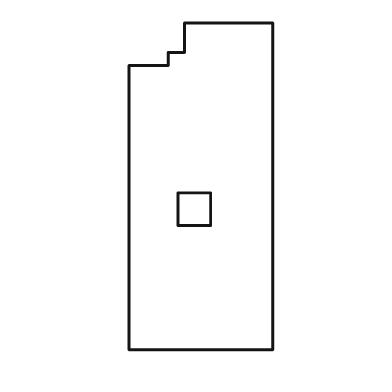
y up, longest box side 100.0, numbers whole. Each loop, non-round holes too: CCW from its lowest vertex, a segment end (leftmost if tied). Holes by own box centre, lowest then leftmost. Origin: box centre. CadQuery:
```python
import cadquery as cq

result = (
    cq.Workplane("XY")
    .moveTo(-22.0, -50.0)
    .lineTo(22.0, -50.0)
    .lineTo(22.0, 50.0)
    .lineTo(-5.0, 50.0)
    .lineTo(-5.0, 41.0)
    .lineTo(-10.0, 41.0)
    .lineTo(-10.0, 37.0)
    .lineTo(-22.0, 37.0)
    .close()
    .moveTo(-7.0, -12.0)
    .lineTo(3.0, -12.0)
    .lineTo(3.0, -2.0)
    .lineTo(-7.0, -2.0)
    .close()
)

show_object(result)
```